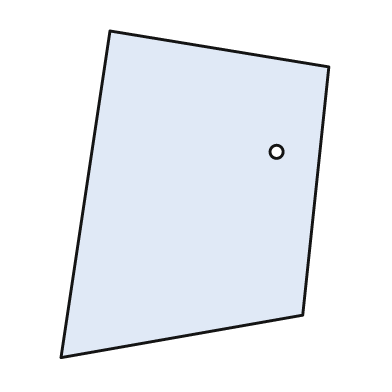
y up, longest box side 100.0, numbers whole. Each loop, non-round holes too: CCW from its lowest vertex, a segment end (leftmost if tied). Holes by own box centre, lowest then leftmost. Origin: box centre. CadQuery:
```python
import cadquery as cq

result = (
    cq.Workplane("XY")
    .moveTo(-41.0, -50.0)
    .lineTo(33.0, -37.0)
    .lineTo(41.0, 39.0)
    .lineTo(-26.0, 50.0)
    .close()
    .moveTo(25.0, 13.0)
    .circle(2.0)
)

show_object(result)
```